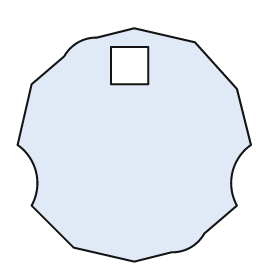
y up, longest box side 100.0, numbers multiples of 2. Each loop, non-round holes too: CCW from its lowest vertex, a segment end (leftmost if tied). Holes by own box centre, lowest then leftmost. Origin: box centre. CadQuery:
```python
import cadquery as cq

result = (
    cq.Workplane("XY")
    .moveTo(0.0, -50.0)
    .lineTo(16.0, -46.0)
    .threePointArc((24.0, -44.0), (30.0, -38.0))
    .lineTo(44.0, -26.0)
    .threePointArc((42.0, -12.0), (50.0, 0.0))
    .lineTo(44.0, 24.0)
    .lineTo(26.0, 44.0)
    .lineTo(0.0, 50.0)
    .lineTo(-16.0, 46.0)
    .threePointArc((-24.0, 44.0), (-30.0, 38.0))
    .lineTo(-44.0, 26.0)
    .lineTo(-50.0, 0.0)
    .threePointArc((-42.0, -12.0), (-44.0, -26.0))
    .lineTo(-26.0, -44.0)
    .close()
    .moveTo(-10.0, 26.0)
    .lineTo(6.0, 26.0)
    .lineTo(6.0, 42.0)
    .lineTo(-10.0, 42.0)
    .close()
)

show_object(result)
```